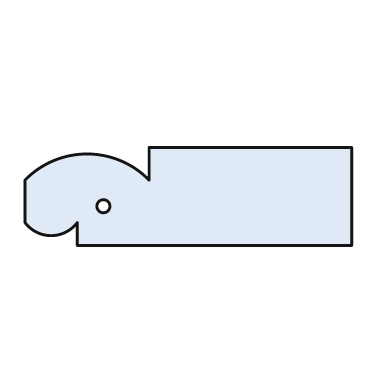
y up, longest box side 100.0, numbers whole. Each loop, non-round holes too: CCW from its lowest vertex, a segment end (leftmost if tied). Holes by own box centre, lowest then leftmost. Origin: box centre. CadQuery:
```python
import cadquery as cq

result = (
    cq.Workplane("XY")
    .moveTo(-34.0, -15.0)
    .lineTo(50.0, -15.0)
    .lineTo(50.0, 15.0)
    .lineTo(-12.0, 15.0)
    .lineTo(-12.0, 5.0)
    .threePointArc((-31.0, 13.0), (-50.0, 5.0))
    .lineTo(-50.0, -8.0)
    .threePointArc((-42.0, -12.0), (-34.0, -8.0))
    .close()
    .moveTo(-26.0, -3.0)
    .circle(2.0)
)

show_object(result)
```